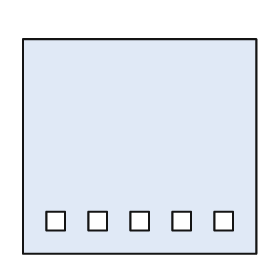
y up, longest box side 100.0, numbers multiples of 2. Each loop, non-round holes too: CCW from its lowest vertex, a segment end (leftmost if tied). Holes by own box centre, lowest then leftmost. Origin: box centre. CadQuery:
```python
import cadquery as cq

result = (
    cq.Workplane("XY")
    .moveTo(-50.0, -46.0)
    .lineTo(50.0, -46.0)
    .lineTo(50.0, 46.0)
    .lineTo(-50.0, 46.0)
    .close()
    .moveTo(-40.0, -36.0)
    .lineTo(-32.0, -36.0)
    .lineTo(-32.0, -28.0)
    .lineTo(-40.0, -28.0)
    .close()
    .moveTo(-22.0, -36.0)
    .lineTo(-14.0, -36.0)
    .lineTo(-14.0, -28.0)
    .lineTo(-22.0, -28.0)
    .close()
    .moveTo(-4.0, -36.0)
    .lineTo(4.0, -36.0)
    .lineTo(4.0, -28.0)
    .lineTo(-4.0, -28.0)
    .close()
    .moveTo(14.0, -36.0)
    .lineTo(22.0, -36.0)
    .lineTo(22.0, -28.0)
    .lineTo(14.0, -28.0)
    .close()
    .moveTo(32.0, -36.0)
    .lineTo(40.0, -36.0)
    .lineTo(40.0, -28.0)
    .lineTo(32.0, -28.0)
    .close()
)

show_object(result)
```